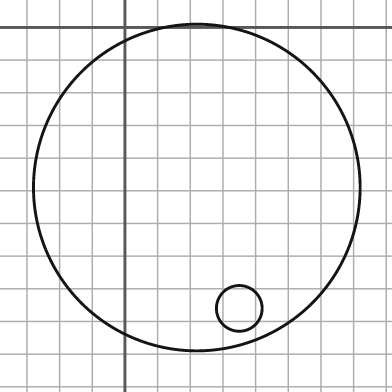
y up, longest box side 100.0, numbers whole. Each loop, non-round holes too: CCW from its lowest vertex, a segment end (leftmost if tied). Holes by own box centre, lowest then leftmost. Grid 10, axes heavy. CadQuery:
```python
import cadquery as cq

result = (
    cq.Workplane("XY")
    .moveTo(22.0, -49.0)
    .circle(50.0)
    .moveTo(35.0, -86.0)
    .circle(7.0)
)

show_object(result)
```